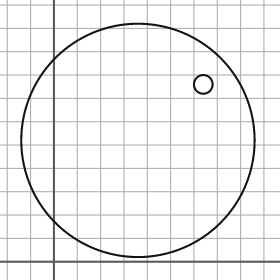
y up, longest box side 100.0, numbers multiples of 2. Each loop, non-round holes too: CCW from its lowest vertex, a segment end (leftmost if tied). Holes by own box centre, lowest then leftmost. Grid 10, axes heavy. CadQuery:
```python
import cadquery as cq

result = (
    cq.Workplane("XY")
    .moveTo(36.0, 52.0)
    .circle(50.0)
    .moveTo(64.0, 76.0)
    .circle(4.0)
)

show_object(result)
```